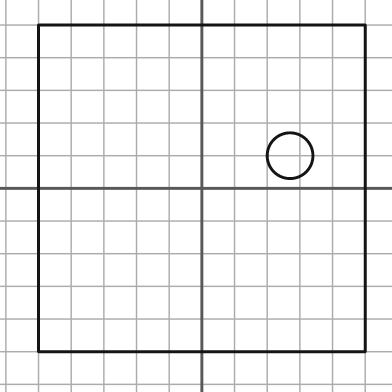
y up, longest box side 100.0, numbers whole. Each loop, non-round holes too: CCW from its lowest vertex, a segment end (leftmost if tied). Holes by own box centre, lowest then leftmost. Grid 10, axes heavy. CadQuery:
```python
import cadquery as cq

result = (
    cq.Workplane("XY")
    .moveTo(-50.0, -50.0)
    .lineTo(50.0, -50.0)
    .lineTo(50.0, 50.0)
    .lineTo(-50.0, 50.0)
    .close()
    .moveTo(27.0, 10.0)
    .circle(7.0)
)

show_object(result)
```